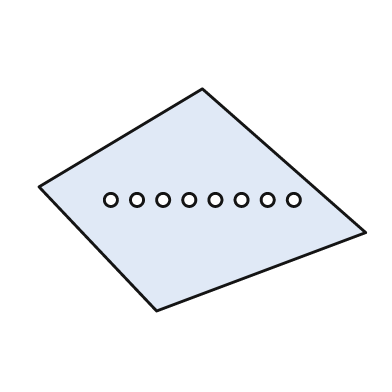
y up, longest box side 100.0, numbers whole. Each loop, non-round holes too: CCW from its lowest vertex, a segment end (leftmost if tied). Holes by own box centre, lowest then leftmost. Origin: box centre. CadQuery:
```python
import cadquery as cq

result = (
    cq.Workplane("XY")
    .moveTo(-14.0, -34.0)
    .lineTo(50.0, -10.0)
    .lineTo(0.0, 34.0)
    .lineTo(-50.0, 4.0)
    .close()
    .moveTo(-28.0, 0.0)
    .circle(2.0)
    .moveTo(-20.0, 0.0)
    .circle(2.0)
    .moveTo(-12.0, 0.0)
    .circle(2.0)
    .moveTo(-4.0, 0.0)
    .circle(2.0)
    .moveTo(4.0, 0.0)
    .circle(2.0)
    .moveTo(12.0, 0.0)
    .circle(2.0)
    .moveTo(20.0, 0.0)
    .circle(2.0)
    .moveTo(28.0, 0.0)
    .circle(2.0)
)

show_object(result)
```